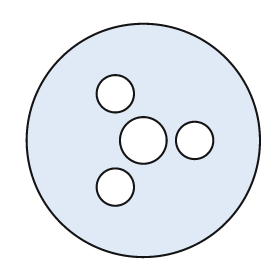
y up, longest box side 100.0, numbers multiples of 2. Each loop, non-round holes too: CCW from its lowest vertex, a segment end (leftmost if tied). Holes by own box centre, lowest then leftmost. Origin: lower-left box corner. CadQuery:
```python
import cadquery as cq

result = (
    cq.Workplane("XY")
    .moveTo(50.0, 50.0)
    .circle(50.0)
    .moveTo(38.0, 30.0)
    .circle(8.0)
    .moveTo(50.0, 50.0)
    .circle(10.0)
    .moveTo(72.0, 50.0)
    .circle(8.0)
    .moveTo(38.0, 70.0)
    .circle(8.0)
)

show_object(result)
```